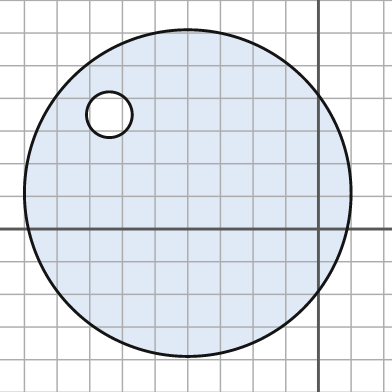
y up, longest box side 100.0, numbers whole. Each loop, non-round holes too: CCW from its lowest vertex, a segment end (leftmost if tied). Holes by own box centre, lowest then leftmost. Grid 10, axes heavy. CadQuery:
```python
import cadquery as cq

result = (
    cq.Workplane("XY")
    .moveTo(-40.0, 11.0)
    .circle(50.0)
    .moveTo(-64.0, 35.0)
    .circle(7.0)
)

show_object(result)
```